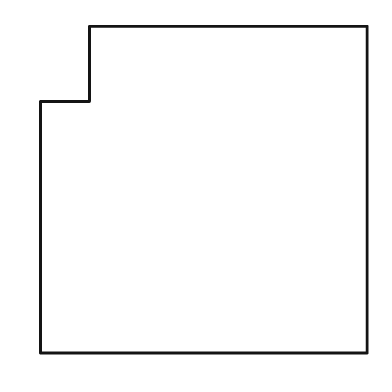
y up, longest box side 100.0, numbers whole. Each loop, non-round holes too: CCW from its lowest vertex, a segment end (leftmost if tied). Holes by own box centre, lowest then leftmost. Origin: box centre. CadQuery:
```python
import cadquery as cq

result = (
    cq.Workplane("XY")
    .moveTo(-50.0, -50.0)
    .lineTo(50.0, -50.0)
    .lineTo(50.0, 50.0)
    .lineTo(-35.0, 50.0)
    .lineTo(-35.0, 27.0)
    .lineTo(-50.0, 27.0)
    .close()
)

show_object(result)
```